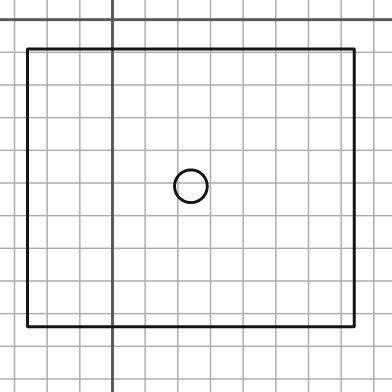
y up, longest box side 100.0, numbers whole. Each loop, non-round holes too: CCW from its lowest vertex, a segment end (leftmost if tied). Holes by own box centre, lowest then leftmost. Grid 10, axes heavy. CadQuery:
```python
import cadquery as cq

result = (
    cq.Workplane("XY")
    .moveTo(-26.0, -94.0)
    .lineTo(74.0, -94.0)
    .lineTo(74.0, -9.0)
    .lineTo(-26.0, -9.0)
    .close()
    .moveTo(24.0, -51.0)
    .circle(5.0)
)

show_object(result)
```